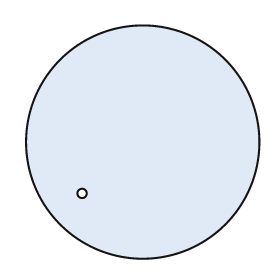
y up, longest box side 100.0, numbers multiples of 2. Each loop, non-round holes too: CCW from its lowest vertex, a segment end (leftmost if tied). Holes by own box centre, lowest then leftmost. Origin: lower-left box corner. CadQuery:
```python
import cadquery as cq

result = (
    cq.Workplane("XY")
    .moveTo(50.0, 50.0)
    .circle(50.0)
    .moveTo(24.0, 28.0)
    .circle(2.0)
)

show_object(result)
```